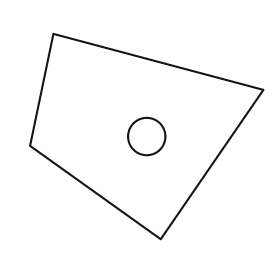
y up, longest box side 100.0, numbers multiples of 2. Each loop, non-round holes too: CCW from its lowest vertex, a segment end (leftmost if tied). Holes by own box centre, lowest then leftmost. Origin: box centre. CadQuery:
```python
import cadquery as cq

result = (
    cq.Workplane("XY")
    .moveTo(6.0, -44.0)
    .lineTo(50.0, 20.0)
    .lineTo(-40.0, 44.0)
    .lineTo(-50.0, -4.0)
    .close()
    .moveTo(0.0, 0.0)
    .circle(8.0)
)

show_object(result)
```